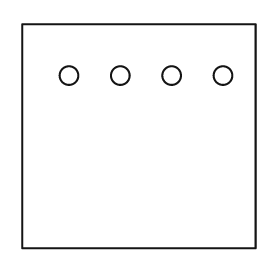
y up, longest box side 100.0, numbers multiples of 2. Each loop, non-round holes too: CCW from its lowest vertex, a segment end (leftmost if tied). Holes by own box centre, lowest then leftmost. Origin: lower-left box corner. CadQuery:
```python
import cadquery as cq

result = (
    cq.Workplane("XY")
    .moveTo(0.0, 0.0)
    .lineTo(100.0, 0.0)
    .lineTo(100.0, 96.0)
    .lineTo(0.0, 96.0)
    .close()
    .moveTo(20.0, 74.0)
    .circle(4.0)
    .moveTo(42.0, 74.0)
    .circle(4.0)
    .moveTo(64.0, 74.0)
    .circle(4.0)
    .moveTo(86.0, 74.0)
    .circle(4.0)
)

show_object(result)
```